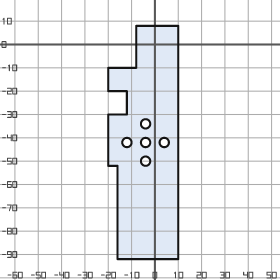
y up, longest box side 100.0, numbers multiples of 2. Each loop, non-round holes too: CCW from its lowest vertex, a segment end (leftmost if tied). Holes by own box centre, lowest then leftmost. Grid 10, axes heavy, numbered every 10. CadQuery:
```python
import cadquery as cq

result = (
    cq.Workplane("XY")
    .moveTo(-16.0, -92.0)
    .lineTo(10.0, -92.0)
    .lineTo(10.0, 8.0)
    .lineTo(-8.0, 8.0)
    .lineTo(-8.0, -10.0)
    .lineTo(-20.0, -10.0)
    .lineTo(-20.0, -20.0)
    .lineTo(-12.0, -20.0)
    .lineTo(-12.0, -30.0)
    .lineTo(-20.0, -30.0)
    .lineTo(-20.0, -52.0)
    .lineTo(-16.0, -52.0)
    .close()
    .moveTo(-4.0, -50.0)
    .circle(2.0)
    .moveTo(-12.0, -42.0)
    .circle(2.0)
    .moveTo(-4.0, -42.0)
    .circle(2.0)
    .moveTo(4.0, -42.0)
    .circle(2.0)
    .moveTo(-4.0, -34.0)
    .circle(2.0)
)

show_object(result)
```